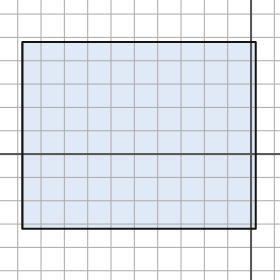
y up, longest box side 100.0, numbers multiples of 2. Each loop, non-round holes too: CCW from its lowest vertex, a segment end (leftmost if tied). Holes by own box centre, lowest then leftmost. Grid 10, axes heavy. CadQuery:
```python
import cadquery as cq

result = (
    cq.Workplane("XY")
    .moveTo(-98.0, -32.0)
    .lineTo(2.0, -32.0)
    .lineTo(2.0, 48.0)
    .lineTo(-98.0, 48.0)
    .close()
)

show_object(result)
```